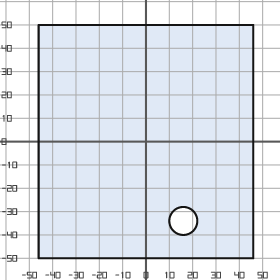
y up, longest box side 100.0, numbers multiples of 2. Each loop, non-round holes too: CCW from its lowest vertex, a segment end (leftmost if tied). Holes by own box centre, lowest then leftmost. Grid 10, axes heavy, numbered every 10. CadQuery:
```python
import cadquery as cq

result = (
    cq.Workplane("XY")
    .moveTo(-46.0, -50.0)
    .lineTo(46.0, -50.0)
    .lineTo(46.0, 50.0)
    .lineTo(-46.0, 50.0)
    .close()
    .moveTo(16.0, -34.0)
    .circle(6.0)
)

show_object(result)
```